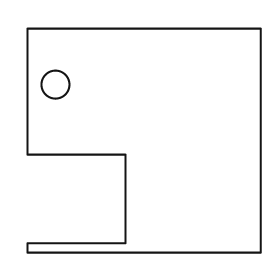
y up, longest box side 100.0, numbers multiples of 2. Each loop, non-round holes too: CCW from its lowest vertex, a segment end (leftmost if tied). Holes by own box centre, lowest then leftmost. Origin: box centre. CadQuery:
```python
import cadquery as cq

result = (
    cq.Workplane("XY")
    .moveTo(-50.0, -48.0)
    .lineTo(50.0, -48.0)
    .lineTo(50.0, 48.0)
    .lineTo(-50.0, 48.0)
    .lineTo(-50.0, -6.0)
    .lineTo(-8.0, -6.0)
    .lineTo(-8.0, -44.0)
    .lineTo(-50.0, -44.0)
    .close()
    .moveTo(-38.0, 24.0)
    .circle(6.0)
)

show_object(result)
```